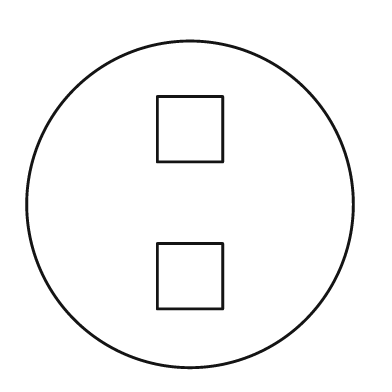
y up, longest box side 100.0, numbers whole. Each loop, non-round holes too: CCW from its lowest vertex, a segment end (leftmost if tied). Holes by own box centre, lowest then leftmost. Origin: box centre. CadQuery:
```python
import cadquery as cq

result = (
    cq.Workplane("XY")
    .moveTo(0.0, 0.0)
    .circle(50.0)
    .moveTo(-10.0, -32.0)
    .lineTo(10.0, -32.0)
    .lineTo(10.0, -12.0)
    .lineTo(-10.0, -12.0)
    .close()
    .moveTo(-10.0, 13.0)
    .lineTo(10.0, 13.0)
    .lineTo(10.0, 33.0)
    .lineTo(-10.0, 33.0)
    .close()
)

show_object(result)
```